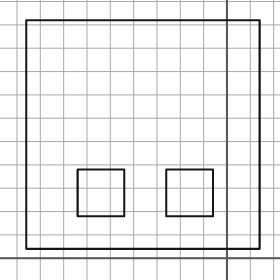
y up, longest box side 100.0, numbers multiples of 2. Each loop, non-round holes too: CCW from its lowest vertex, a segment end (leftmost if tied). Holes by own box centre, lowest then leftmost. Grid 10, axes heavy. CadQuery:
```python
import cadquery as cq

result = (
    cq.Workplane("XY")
    .moveTo(-86.0, 4.0)
    .lineTo(14.0, 4.0)
    .lineTo(14.0, 102.0)
    .lineTo(-86.0, 102.0)
    .close()
    .moveTo(-64.0, 18.0)
    .lineTo(-44.0, 18.0)
    .lineTo(-44.0, 38.0)
    .lineTo(-64.0, 38.0)
    .close()
    .moveTo(-26.0, 18.0)
    .lineTo(-6.0, 18.0)
    .lineTo(-6.0, 38.0)
    .lineTo(-26.0, 38.0)
    .close()
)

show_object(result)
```